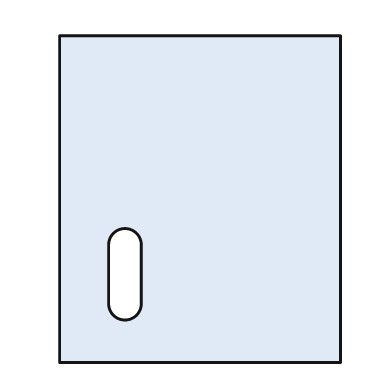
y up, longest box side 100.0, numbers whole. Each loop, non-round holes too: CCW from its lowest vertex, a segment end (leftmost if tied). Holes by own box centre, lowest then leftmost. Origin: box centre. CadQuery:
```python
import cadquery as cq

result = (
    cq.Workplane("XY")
    .moveTo(-43.0, -50.0)
    .lineTo(43.0, -50.0)
    .lineTo(43.0, 50.0)
    .lineTo(-43.0, 50.0)
    .close()
    .moveTo(-28.0, -32.0)
    .threePointArc((-23.0, -37.0), (-18.0, -32.0))
    .lineTo(-18.0, -14.0)
    .threePointArc((-23.0, -9.0), (-28.0, -14.0))
    .close()
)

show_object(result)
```